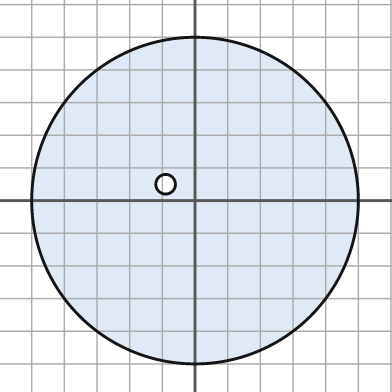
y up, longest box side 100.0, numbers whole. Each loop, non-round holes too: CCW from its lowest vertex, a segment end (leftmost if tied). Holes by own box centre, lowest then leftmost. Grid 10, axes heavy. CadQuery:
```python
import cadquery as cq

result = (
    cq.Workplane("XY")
    .moveTo(0.0, 0.0)
    .circle(50.0)
    .moveTo(-9.0, 5.0)
    .circle(3.0)
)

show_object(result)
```